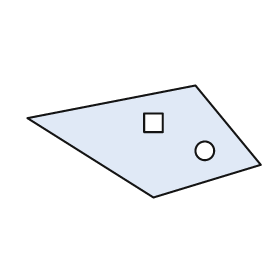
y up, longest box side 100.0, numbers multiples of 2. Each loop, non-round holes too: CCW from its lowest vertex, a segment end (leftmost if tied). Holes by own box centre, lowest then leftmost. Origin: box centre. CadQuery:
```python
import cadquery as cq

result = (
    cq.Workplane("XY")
    .moveTo(4.0, -24.0)
    .lineTo(50.0, -10.0)
    .lineTo(22.0, 24.0)
    .lineTo(-50.0, 10.0)
    .close()
    .moveTo(26.0, -4.0)
    .circle(4.0)
    .moveTo(0.0, 4.0)
    .lineTo(8.0, 4.0)
    .lineTo(8.0, 12.0)
    .lineTo(0.0, 12.0)
    .close()
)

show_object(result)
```